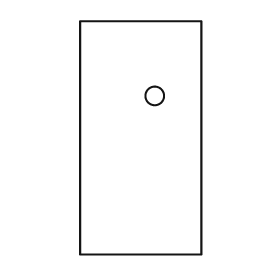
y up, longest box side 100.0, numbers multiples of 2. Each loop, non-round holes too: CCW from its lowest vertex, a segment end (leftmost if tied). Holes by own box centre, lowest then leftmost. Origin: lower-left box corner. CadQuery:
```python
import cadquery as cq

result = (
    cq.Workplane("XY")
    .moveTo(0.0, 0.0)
    .lineTo(52.0, 0.0)
    .lineTo(52.0, 100.0)
    .lineTo(0.0, 100.0)
    .close()
    .moveTo(32.0, 68.0)
    .circle(4.0)
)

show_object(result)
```